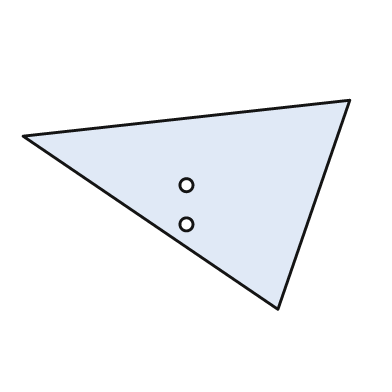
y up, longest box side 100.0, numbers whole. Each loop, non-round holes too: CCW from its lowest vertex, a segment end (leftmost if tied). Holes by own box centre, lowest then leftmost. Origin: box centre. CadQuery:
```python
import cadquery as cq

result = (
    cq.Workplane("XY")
    .moveTo(28.0, -32.0)
    .lineTo(50.0, 32.0)
    .lineTo(-50.0, 21.0)
    .close()
    .moveTo(0.0, -6.0)
    .circle(2.0)
    .moveTo(0.0, 6.0)
    .circle(2.0)
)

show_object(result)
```